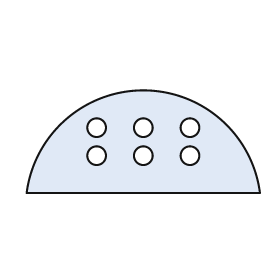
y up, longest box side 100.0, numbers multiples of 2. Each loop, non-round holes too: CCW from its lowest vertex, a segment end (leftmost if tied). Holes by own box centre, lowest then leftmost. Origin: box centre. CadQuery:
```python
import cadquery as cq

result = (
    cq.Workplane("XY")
    .moveTo(-50.0, -22.0)
    .lineTo(50.0, -22.0)
    .threePointArc((0.0, 22.0), (-50.0, -22.0))
    .close()
    .moveTo(-20.0, -6.0)
    .circle(4.0)
    .moveTo(0.0, -6.0)
    .circle(4.0)
    .moveTo(20.0, -6.0)
    .circle(4.0)
    .moveTo(-20.0, 6.0)
    .circle(4.0)
    .moveTo(0.0, 6.0)
    .circle(4.0)
    .moveTo(20.0, 6.0)
    .circle(4.0)
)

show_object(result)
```